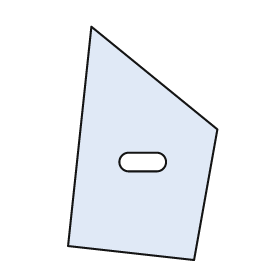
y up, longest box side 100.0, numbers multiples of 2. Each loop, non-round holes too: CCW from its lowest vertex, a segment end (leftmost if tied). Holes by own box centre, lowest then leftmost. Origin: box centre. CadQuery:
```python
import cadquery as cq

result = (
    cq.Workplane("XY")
    .moveTo(22.0, -50.0)
    .lineTo(32.0, 6.0)
    .lineTo(-22.0, 50.0)
    .lineTo(-32.0, -44.0)
    .close()
    .moveTo(-6.0, -12.0)
    .lineTo(6.0, -12.0)
    .threePointArc((10.0, -8.0), (6.0, -4.0))
    .lineTo(-6.0, -4.0)
    .threePointArc((-10.0, -8.0), (-6.0, -12.0))
    .close()
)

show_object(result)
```